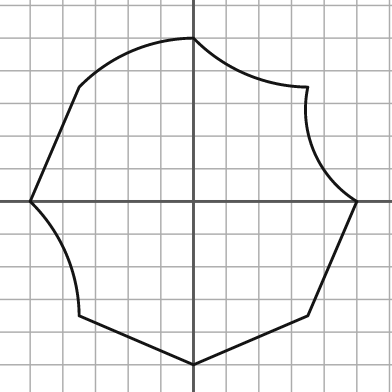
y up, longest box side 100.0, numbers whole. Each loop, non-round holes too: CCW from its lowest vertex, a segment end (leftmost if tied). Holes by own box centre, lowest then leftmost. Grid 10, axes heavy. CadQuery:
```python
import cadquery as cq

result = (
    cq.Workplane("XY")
    .moveTo(0.0, -50.0)
    .lineTo(35.0, -35.0)
    .lineTo(50.0, 0.0)
    .threePointArc((37.0, 15.0), (35.0, 35.0))
    .threePointArc((16.0, 39.0), (0.0, 50.0))
    .threePointArc((-19.0, 46.0), (-35.0, 35.0))
    .lineTo(-50.0, 0.0)
    .threePointArc((-39.0, -16.0), (-35.0, -35.0))
    .close()
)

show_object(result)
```